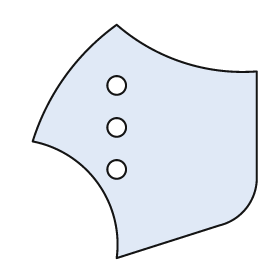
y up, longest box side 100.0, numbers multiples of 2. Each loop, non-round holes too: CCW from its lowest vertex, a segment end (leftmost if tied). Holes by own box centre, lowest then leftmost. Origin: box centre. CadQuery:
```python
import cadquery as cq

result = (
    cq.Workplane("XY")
    .moveTo(-12.0, -50.0)
    .lineTo(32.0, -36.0)
    .threePointArc((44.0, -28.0), (48.0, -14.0))
    .lineTo(48.0, 30.0)
    .threePointArc((16.0, 34.0), (-12.0, 50.0))
    .threePointArc((-34.0, 28.0), (-48.0, 0.0))
    .threePointArc((-20.0, -18.0), (-12.0, -50.0))
    .close()
    .moveTo(-12.0, -12.0)
    .circle(4.0)
    .moveTo(-12.0, 6.0)
    .circle(4.0)
    .moveTo(-12.0, 24.0)
    .circle(4.0)
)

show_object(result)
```